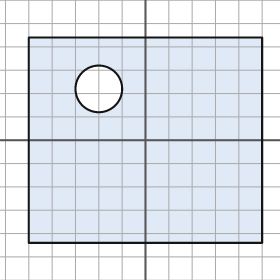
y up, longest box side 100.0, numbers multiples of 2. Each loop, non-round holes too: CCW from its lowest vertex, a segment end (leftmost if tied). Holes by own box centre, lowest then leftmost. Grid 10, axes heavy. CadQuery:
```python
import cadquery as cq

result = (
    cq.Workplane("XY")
    .moveTo(-50.0, -44.0)
    .lineTo(50.0, -44.0)
    .lineTo(50.0, 44.0)
    .lineTo(-50.0, 44.0)
    .close()
    .moveTo(-20.0, 22.0)
    .circle(10.0)
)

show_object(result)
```